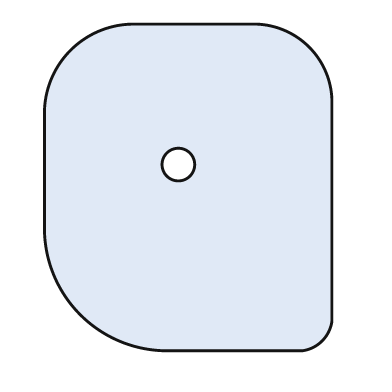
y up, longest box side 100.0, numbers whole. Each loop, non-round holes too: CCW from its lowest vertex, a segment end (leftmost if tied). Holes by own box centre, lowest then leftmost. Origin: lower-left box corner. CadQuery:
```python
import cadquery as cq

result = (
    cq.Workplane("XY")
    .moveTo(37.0, 0.0)
    .lineTo(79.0, 0.0)
    .threePointArc((85.0, 3.0), (88.0, 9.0))
    .lineTo(88.0, 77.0)
    .threePointArc((81.0, 93.0), (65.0, 100.0))
    .lineTo(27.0, 100.0)
    .threePointArc((8.0, 92.0), (0.0, 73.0))
    .lineTo(0.0, 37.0)
    .threePointArc((11.0, 11.0), (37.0, 0.0))
    .close()
    .moveTo(41.0, 57.0)
    .circle(5.0)
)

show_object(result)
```